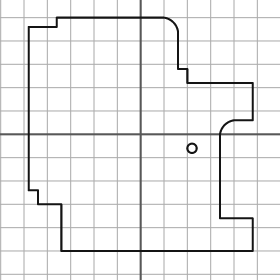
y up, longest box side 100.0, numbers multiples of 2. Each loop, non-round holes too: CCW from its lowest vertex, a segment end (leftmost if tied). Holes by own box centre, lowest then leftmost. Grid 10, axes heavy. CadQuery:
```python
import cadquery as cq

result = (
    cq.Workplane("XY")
    .moveTo(-34.0, -50.0)
    .lineTo(48.0, -50.0)
    .lineTo(48.0, -36.0)
    .lineTo(34.0, -36.0)
    .lineTo(34.0, 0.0)
    .threePointArc((36.0, 4.0), (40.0, 6.0))
    .lineTo(48.0, 6.0)
    .lineTo(48.0, 22.0)
    .lineTo(20.0, 22.0)
    .lineTo(20.0, 28.0)
    .lineTo(16.0, 28.0)
    .lineTo(16.0, 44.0)
    .threePointArc((14.0, 48.0), (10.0, 50.0))
    .lineTo(-36.0, 50.0)
    .lineTo(-36.0, 46.0)
    .lineTo(-48.0, 46.0)
    .lineTo(-48.0, -24.0)
    .lineTo(-44.0, -24.0)
    .lineTo(-44.0, -30.0)
    .lineTo(-34.0, -30.0)
    .close()
    .moveTo(22.0, -6.0)
    .circle(2.0)
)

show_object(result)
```